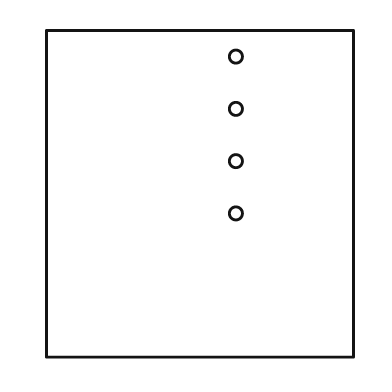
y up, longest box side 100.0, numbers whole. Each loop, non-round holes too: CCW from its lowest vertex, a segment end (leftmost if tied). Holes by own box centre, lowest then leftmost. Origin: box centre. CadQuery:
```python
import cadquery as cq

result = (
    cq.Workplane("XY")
    .moveTo(-47.0, -50.0)
    .lineTo(47.0, -50.0)
    .lineTo(47.0, 50.0)
    .lineTo(-47.0, 50.0)
    .close()
    .moveTo(11.0, -6.0)
    .circle(2.0)
    .moveTo(11.0, 10.0)
    .circle(2.0)
    .moveTo(11.0, 26.0)
    .circle(2.0)
    .moveTo(11.0, 42.0)
    .circle(2.0)
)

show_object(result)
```